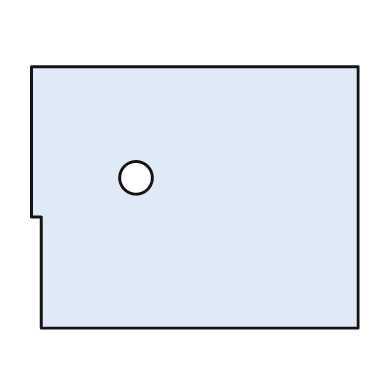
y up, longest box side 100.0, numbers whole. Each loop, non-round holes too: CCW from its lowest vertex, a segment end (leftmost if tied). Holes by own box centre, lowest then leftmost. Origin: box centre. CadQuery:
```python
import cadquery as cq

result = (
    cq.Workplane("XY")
    .moveTo(-47.0, -40.0)
    .lineTo(50.0, -40.0)
    .lineTo(50.0, 40.0)
    .lineTo(-50.0, 40.0)
    .lineTo(-50.0, -6.0)
    .lineTo(-47.0, -6.0)
    .close()
    .moveTo(-18.0, 6.0)
    .circle(5.0)
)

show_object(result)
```